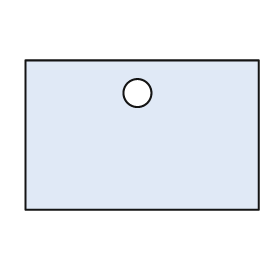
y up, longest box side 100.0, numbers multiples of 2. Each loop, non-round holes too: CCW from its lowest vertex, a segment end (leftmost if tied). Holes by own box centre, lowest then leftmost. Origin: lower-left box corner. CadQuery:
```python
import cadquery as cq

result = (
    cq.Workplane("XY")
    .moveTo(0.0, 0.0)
    .lineTo(100.0, 0.0)
    .lineTo(100.0, 64.0)
    .lineTo(0.0, 64.0)
    .close()
    .moveTo(48.0, 50.0)
    .circle(6.0)
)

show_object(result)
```